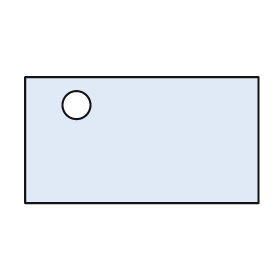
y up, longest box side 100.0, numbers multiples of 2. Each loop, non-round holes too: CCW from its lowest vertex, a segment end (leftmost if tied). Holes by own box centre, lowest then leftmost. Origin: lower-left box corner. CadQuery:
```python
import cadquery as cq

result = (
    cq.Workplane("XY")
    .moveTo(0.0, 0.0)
    .lineTo(100.0, 0.0)
    .lineTo(100.0, 54.0)
    .lineTo(0.0, 54.0)
    .close()
    .moveTo(22.0, 42.0)
    .circle(6.0)
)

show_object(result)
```